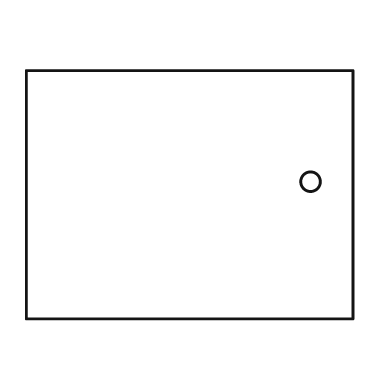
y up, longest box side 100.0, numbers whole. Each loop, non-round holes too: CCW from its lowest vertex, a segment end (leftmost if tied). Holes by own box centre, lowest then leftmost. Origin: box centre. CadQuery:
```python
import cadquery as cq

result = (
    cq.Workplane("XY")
    .moveTo(-50.0, -38.0)
    .lineTo(50.0, -38.0)
    .lineTo(50.0, 38.0)
    .lineTo(-50.0, 38.0)
    .close()
    .moveTo(37.0, 4.0)
    .circle(3.0)
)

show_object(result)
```